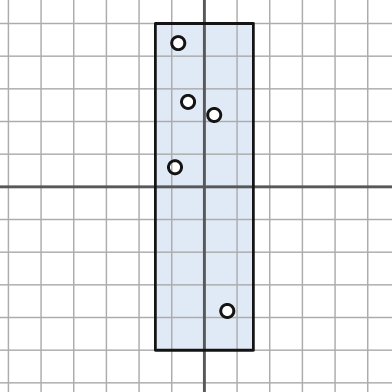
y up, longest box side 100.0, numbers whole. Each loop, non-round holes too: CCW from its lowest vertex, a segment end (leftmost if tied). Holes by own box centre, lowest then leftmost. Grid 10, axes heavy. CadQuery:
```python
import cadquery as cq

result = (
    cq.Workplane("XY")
    .moveTo(-15.0, -50.0)
    .lineTo(15.0, -50.0)
    .lineTo(15.0, 50.0)
    .lineTo(-15.0, 50.0)
    .close()
    .moveTo(7.0, -38.0)
    .circle(2.0)
    .moveTo(-9.0, 6.0)
    .circle(2.0)
    .moveTo(3.0, 22.0)
    .circle(2.0)
    .moveTo(-5.0, 26.0)
    .circle(2.0)
    .moveTo(-8.0, 44.0)
    .circle(2.0)
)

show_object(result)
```